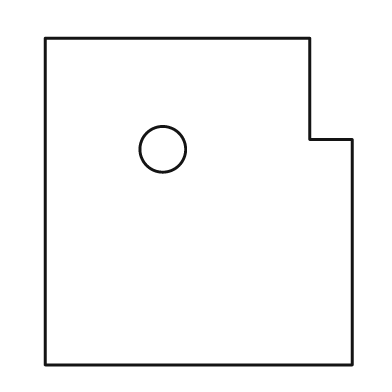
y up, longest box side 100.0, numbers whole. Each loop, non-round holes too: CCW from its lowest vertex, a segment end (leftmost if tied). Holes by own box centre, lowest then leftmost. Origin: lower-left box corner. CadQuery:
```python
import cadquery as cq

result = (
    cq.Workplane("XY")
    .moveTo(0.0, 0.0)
    .lineTo(94.0, 0.0)
    .lineTo(94.0, 69.0)
    .lineTo(81.0, 69.0)
    .lineTo(81.0, 100.0)
    .lineTo(0.0, 100.0)
    .close()
    .moveTo(36.0, 66.0)
    .circle(7.0)
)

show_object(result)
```